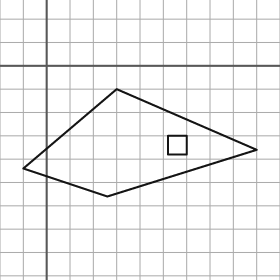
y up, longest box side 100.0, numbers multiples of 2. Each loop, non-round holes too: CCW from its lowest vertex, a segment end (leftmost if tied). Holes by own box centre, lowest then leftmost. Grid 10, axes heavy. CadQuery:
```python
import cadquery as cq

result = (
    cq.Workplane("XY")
    .moveTo(26.0, -56.0)
    .lineTo(90.0, -36.0)
    .lineTo(30.0, -10.0)
    .lineTo(-10.0, -44.0)
    .close()
    .moveTo(52.0, -38.0)
    .lineTo(60.0, -38.0)
    .lineTo(60.0, -30.0)
    .lineTo(52.0, -30.0)
    .close()
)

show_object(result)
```